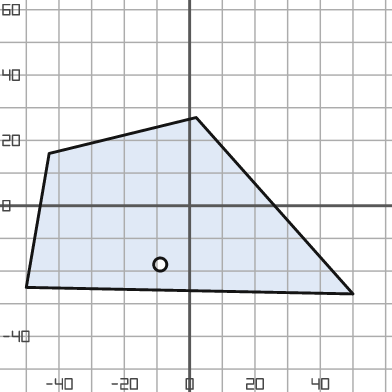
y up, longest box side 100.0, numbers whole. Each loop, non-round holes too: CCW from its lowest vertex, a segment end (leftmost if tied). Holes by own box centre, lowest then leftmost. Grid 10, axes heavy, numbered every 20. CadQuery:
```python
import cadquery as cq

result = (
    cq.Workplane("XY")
    .moveTo(50.0, -27.0)
    .lineTo(2.0, 27.0)
    .lineTo(-43.0, 16.0)
    .lineTo(-50.0, -25.0)
    .close()
    .moveTo(-9.0, -18.0)
    .circle(2.0)
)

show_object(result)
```